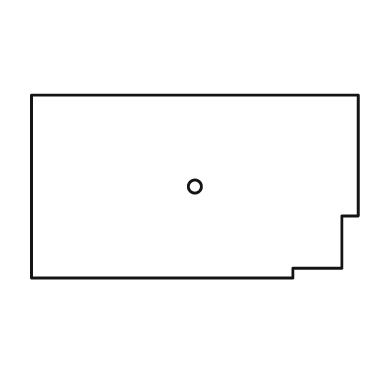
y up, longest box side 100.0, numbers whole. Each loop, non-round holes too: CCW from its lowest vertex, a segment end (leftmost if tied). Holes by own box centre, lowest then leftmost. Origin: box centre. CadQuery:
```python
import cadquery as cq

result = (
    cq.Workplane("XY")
    .moveTo(-50.0, -28.0)
    .lineTo(30.0, -28.0)
    .lineTo(30.0, -25.0)
    .lineTo(45.0, -25.0)
    .lineTo(45.0, -9.0)
    .lineTo(50.0, -9.0)
    .lineTo(50.0, 28.0)
    .lineTo(-50.0, 28.0)
    .close()
    .moveTo(0.0, 0.0)
    .circle(2.0)
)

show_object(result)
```